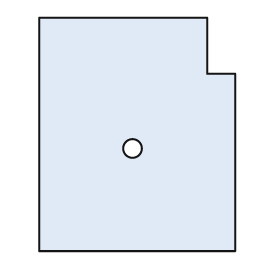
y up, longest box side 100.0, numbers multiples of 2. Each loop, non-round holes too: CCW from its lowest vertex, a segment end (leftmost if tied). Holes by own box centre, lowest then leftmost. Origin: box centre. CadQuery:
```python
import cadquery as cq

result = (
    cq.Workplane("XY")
    .moveTo(-42.0, -50.0)
    .lineTo(42.0, -50.0)
    .lineTo(42.0, 26.0)
    .lineTo(30.0, 26.0)
    .lineTo(30.0, 50.0)
    .lineTo(-42.0, 50.0)
    .close()
    .moveTo(-2.0, -6.0)
    .circle(4.0)
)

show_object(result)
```